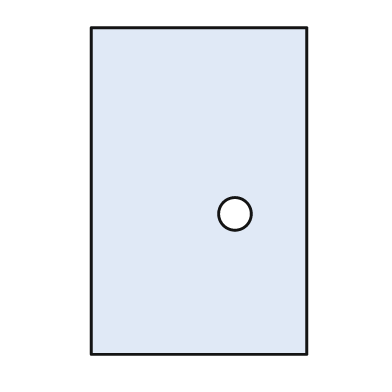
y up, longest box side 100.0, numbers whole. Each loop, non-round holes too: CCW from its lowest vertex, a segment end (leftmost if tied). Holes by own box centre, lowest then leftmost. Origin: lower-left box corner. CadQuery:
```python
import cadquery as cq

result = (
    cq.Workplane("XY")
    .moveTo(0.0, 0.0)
    .lineTo(66.0, 0.0)
    .lineTo(66.0, 100.0)
    .lineTo(0.0, 100.0)
    .close()
    .moveTo(44.0, 43.0)
    .circle(5.0)
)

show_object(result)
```